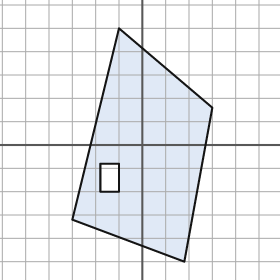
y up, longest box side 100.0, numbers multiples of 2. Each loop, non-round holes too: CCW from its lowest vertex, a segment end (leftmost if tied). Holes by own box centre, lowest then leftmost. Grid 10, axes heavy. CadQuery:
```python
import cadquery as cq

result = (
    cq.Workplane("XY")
    .moveTo(18.0, -50.0)
    .lineTo(30.0, 16.0)
    .lineTo(-10.0, 50.0)
    .lineTo(-30.0, -32.0)
    .close()
    .moveTo(-18.0, -20.0)
    .lineTo(-10.0, -20.0)
    .lineTo(-10.0, -8.0)
    .lineTo(-18.0, -8.0)
    .close()
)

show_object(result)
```